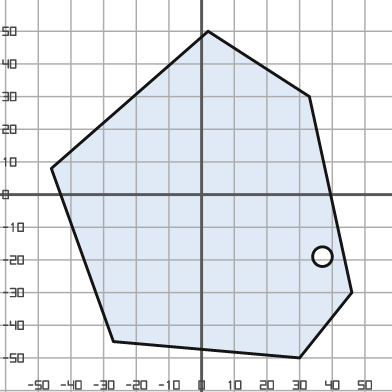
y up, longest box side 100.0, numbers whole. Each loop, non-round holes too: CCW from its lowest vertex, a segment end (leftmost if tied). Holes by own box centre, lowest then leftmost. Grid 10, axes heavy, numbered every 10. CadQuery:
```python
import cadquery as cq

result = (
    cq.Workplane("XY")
    .moveTo(30.0, -50.0)
    .lineTo(46.0, -30.0)
    .lineTo(33.0, 30.0)
    .lineTo(2.0, 50.0)
    .lineTo(-46.0, 8.0)
    .lineTo(-27.0, -45.0)
    .close()
    .moveTo(37.0, -19.0)
    .circle(3.0)
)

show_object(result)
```